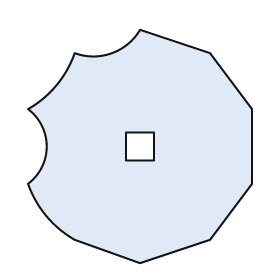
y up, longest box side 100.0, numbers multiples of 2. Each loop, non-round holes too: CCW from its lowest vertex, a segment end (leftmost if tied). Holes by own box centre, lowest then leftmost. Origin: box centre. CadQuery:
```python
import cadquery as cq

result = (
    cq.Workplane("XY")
    .moveTo(0.0, -50.0)
    .lineTo(30.0, -40.0)
    .lineTo(48.0, -16.0)
    .lineTo(48.0, 16.0)
    .lineTo(30.0, 40.0)
    .lineTo(0.0, 50.0)
    .threePointArc((-12.0, 40.0), (-28.0, 40.0))
    .threePointArc((-36.0, 26.0), (-48.0, 16.0))
    .threePointArc((-40.0, 0.0), (-48.0, -16.0))
    .threePointArc((-40.0, -30.0), (-28.0, -40.0))
    .close()
    .moveTo(-6.0, -6.0)
    .lineTo(6.0, -6.0)
    .lineTo(6.0, 6.0)
    .lineTo(-6.0, 6.0)
    .close()
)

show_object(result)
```